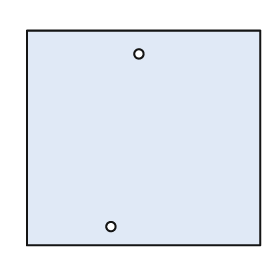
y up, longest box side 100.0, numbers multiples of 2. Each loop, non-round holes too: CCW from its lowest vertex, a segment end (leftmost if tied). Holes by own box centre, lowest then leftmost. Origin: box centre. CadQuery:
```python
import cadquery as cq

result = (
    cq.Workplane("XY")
    .moveTo(-50.0, -46.0)
    .lineTo(50.0, -46.0)
    .lineTo(50.0, 46.0)
    .lineTo(-50.0, 46.0)
    .close()
    .moveTo(-14.0, -38.0)
    .circle(2.0)
    .moveTo(-2.0, 36.0)
    .circle(2.0)
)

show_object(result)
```